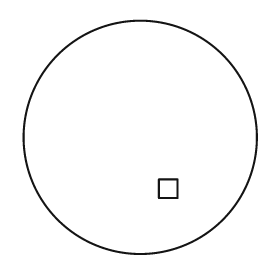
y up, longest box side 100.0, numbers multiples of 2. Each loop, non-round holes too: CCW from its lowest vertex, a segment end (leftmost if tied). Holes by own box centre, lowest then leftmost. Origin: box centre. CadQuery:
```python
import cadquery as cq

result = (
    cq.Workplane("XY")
    .moveTo(0.0, 0.0)
    .circle(50.0)
    .moveTo(8.0, -26.0)
    .lineTo(16.0, -26.0)
    .lineTo(16.0, -18.0)
    .lineTo(8.0, -18.0)
    .close()
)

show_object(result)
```